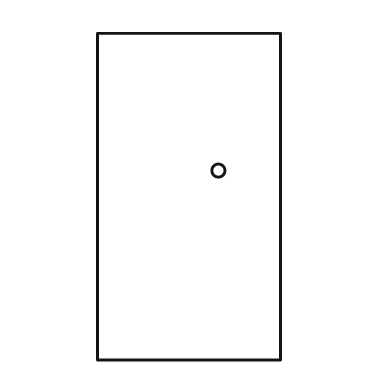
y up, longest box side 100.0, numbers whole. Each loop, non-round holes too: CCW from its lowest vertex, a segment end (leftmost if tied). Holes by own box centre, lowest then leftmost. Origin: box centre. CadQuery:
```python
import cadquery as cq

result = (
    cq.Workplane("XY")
    .moveTo(-28.0, -50.0)
    .lineTo(28.0, -50.0)
    .lineTo(28.0, 50.0)
    .lineTo(-28.0, 50.0)
    .close()
    .moveTo(9.0, 8.0)
    .circle(2.0)
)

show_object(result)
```